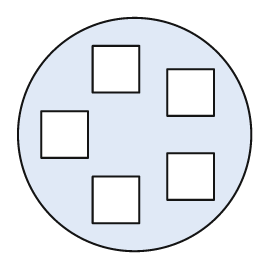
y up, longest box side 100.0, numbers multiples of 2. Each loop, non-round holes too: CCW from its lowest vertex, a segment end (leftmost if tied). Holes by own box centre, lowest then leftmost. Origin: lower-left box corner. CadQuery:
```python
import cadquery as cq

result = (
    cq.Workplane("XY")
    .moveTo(50.0, 50.0)
    .circle(50.0)
    .moveTo(32.0, 12.0)
    .lineTo(52.0, 12.0)
    .lineTo(52.0, 32.0)
    .lineTo(32.0, 32.0)
    .close()
    .moveTo(64.0, 22.0)
    .lineTo(84.0, 22.0)
    .lineTo(84.0, 42.0)
    .lineTo(64.0, 42.0)
    .close()
    .moveTo(10.0, 40.0)
    .lineTo(30.0, 40.0)
    .lineTo(30.0, 60.0)
    .lineTo(10.0, 60.0)
    .close()
    .moveTo(64.0, 58.0)
    .lineTo(84.0, 58.0)
    .lineTo(84.0, 78.0)
    .lineTo(64.0, 78.0)
    .close()
    .moveTo(32.0, 68.0)
    .lineTo(52.0, 68.0)
    .lineTo(52.0, 88.0)
    .lineTo(32.0, 88.0)
    .close()
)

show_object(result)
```